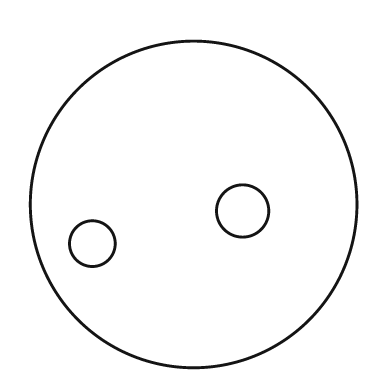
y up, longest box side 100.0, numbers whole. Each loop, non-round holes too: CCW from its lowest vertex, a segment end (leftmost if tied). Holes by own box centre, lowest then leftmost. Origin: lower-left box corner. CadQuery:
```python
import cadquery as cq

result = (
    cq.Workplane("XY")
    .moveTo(50.0, 50.0)
    .circle(50.0)
    .moveTo(19.0, 38.0)
    .circle(7.0)
    .moveTo(65.0, 48.0)
    .circle(8.0)
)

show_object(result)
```